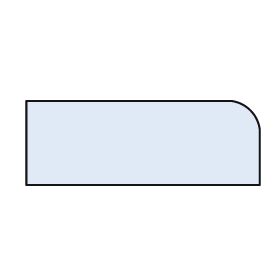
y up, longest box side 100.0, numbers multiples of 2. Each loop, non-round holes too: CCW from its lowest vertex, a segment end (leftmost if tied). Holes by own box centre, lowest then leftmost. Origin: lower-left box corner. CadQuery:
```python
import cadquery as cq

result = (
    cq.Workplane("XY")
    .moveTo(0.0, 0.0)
    .lineTo(100.0, 0.0)
    .lineTo(100.0, 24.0)
    .threePointArc((96.0, 32.0), (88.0, 36.0))
    .lineTo(0.0, 36.0)
    .close()
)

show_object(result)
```